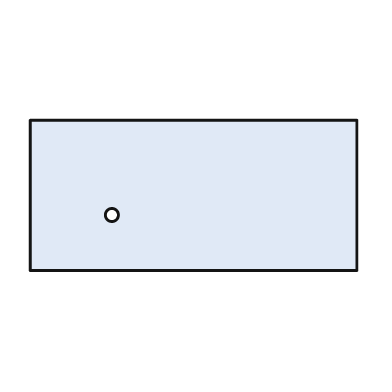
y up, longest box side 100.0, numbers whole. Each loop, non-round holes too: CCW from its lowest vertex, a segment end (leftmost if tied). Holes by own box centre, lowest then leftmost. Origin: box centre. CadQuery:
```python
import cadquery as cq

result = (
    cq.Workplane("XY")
    .moveTo(-50.0, -23.0)
    .lineTo(50.0, -23.0)
    .lineTo(50.0, 23.0)
    .lineTo(-50.0, 23.0)
    .close()
    .moveTo(-25.0, -6.0)
    .circle(2.0)
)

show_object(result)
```